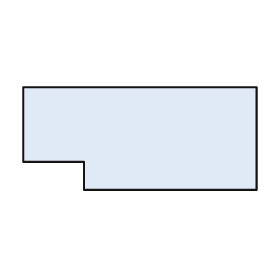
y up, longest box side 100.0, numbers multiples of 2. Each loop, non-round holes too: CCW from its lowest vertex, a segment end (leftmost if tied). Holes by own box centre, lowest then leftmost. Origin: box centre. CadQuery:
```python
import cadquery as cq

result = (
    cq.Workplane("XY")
    .moveTo(-24.0, -22.0)
    .lineTo(50.0, -22.0)
    .lineTo(50.0, 22.0)
    .lineTo(-50.0, 22.0)
    .lineTo(-50.0, -10.0)
    .lineTo(-24.0, -10.0)
    .close()
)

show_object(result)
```